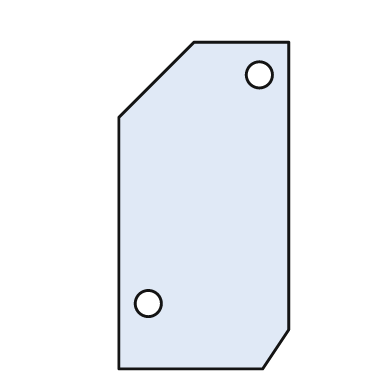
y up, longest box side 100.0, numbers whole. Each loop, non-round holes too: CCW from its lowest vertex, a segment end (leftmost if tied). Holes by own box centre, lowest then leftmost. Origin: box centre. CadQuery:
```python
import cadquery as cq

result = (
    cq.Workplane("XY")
    .moveTo(-26.0, -50.0)
    .lineTo(18.0, -50.0)
    .lineTo(26.0, -38.0)
    .lineTo(26.0, 50.0)
    .lineTo(-3.0, 50.0)
    .lineTo(-26.0, 27.0)
    .close()
    .moveTo(-17.0, -30.0)
    .circle(4.0)
    .moveTo(17.0, 40.0)
    .circle(4.0)
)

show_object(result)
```